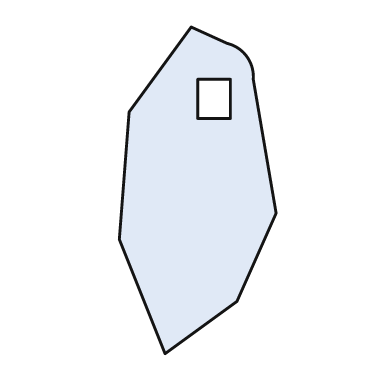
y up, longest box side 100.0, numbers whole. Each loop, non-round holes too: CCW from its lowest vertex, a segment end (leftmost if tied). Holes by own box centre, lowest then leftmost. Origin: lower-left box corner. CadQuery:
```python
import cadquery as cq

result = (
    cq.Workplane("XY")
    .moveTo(14.0, 0.0)
    .lineTo(36.0, 16.0)
    .lineTo(48.0, 43.0)
    .lineTo(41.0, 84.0)
    .threePointArc((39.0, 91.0), (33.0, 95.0))
    .lineTo(22.0, 100.0)
    .lineTo(3.0, 74.0)
    .lineTo(0.0, 35.0)
    .close()
    .moveTo(24.0, 72.0)
    .lineTo(34.0, 72.0)
    .lineTo(34.0, 84.0)
    .lineTo(24.0, 84.0)
    .close()
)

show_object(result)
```